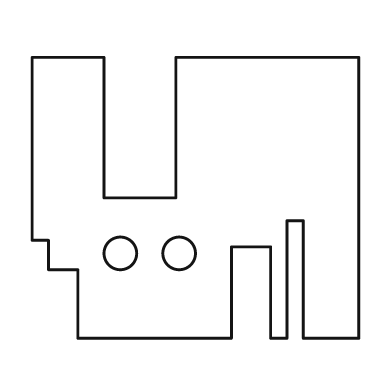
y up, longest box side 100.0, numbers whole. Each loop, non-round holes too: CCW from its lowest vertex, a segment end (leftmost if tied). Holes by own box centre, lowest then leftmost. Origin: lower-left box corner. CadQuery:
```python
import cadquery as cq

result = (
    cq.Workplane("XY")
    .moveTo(14.0, 0.0)
    .lineTo(61.0, 0.0)
    .lineTo(61.0, 28.0)
    .lineTo(73.0, 28.0)
    .lineTo(73.0, 0.0)
    .lineTo(78.0, 0.0)
    .lineTo(78.0, 36.0)
    .lineTo(83.0, 36.0)
    .lineTo(83.0, 0.0)
    .lineTo(100.0, 0.0)
    .lineTo(100.0, 86.0)
    .lineTo(44.0, 86.0)
    .lineTo(44.0, 43.0)
    .lineTo(22.0, 43.0)
    .lineTo(22.0, 86.0)
    .lineTo(0.0, 86.0)
    .lineTo(0.0, 30.0)
    .lineTo(5.0, 30.0)
    .lineTo(5.0, 21.0)
    .lineTo(14.0, 21.0)
    .close()
    .moveTo(27.0, 26.0)
    .circle(5.0)
    .moveTo(45.0, 26.0)
    .circle(5.0)
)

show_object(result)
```